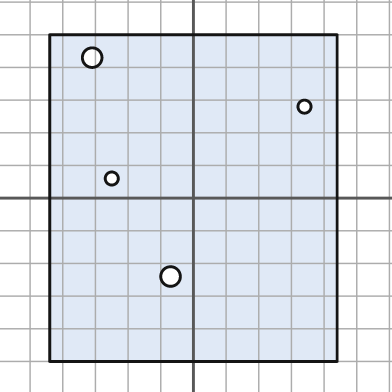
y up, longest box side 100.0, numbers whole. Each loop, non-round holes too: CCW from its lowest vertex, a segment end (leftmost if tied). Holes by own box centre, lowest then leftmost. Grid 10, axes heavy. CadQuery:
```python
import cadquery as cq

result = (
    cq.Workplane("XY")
    .moveTo(-44.0, -50.0)
    .lineTo(44.0, -50.0)
    .lineTo(44.0, 50.0)
    .lineTo(-44.0, 50.0)
    .close()
    .moveTo(-7.0, -24.0)
    .circle(3.0)
    .moveTo(-25.0, 6.0)
    .circle(2.0)
    .moveTo(34.0, 28.0)
    .circle(2.0)
    .moveTo(-31.0, 43.0)
    .circle(3.0)
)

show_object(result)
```